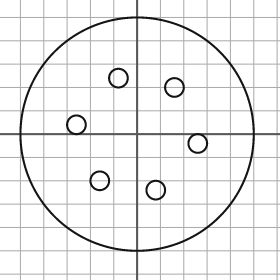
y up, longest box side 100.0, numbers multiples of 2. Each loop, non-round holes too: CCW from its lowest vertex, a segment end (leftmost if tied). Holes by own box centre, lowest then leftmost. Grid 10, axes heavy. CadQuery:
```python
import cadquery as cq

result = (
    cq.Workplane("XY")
    .moveTo(0.0, 0.0)
    .circle(50.0)
    .moveTo(8.0, -24.0)
    .circle(4.0)
    .moveTo(-16.0, -20.0)
    .circle(4.0)
    .moveTo(26.0, -4.0)
    .circle(4.0)
    .moveTo(-26.0, 4.0)
    .circle(4.0)
    .moveTo(16.0, 20.0)
    .circle(4.0)
    .moveTo(-8.0, 24.0)
    .circle(4.0)
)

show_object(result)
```